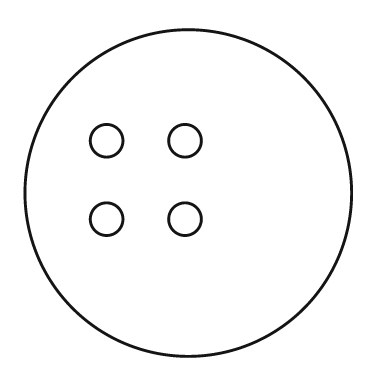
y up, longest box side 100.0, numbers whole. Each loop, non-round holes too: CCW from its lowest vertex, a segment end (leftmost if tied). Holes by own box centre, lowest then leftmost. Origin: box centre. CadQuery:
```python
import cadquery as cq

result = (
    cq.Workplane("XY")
    .moveTo(0.0, 0.0)
    .circle(50.0)
    .moveTo(-25.0, -8.0)
    .circle(5.0)
    .moveTo(-1.0, -8.0)
    .circle(5.0)
    .moveTo(-25.0, 16.0)
    .circle(5.0)
    .moveTo(-1.0, 16.0)
    .circle(5.0)
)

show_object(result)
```